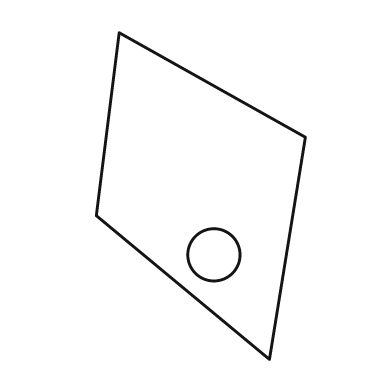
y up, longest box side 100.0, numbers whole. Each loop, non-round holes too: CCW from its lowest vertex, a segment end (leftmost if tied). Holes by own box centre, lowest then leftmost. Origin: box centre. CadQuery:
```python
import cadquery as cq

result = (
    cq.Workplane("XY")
    .moveTo(21.0, -50.0)
    .lineTo(32.0, 18.0)
    .lineTo(-25.0, 50.0)
    .lineTo(-32.0, -6.0)
    .close()
    .moveTo(4.0, -18.0)
    .circle(8.0)
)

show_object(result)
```